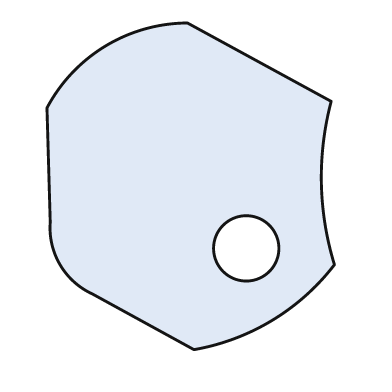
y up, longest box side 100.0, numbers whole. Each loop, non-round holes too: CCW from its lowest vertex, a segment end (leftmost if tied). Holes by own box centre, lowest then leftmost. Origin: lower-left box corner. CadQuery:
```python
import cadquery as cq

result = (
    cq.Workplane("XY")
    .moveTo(45.0, 0.0)
    .threePointArc((69.0, 9.0), (88.0, 26.0))
    .threePointArc((84.0, 51.0), (87.0, 76.0))
    .lineTo(43.0, 100.0)
    .threePointArc((18.0, 93.0), (0.0, 74.0))
    .lineTo(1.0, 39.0)
    .threePointArc((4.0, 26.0), (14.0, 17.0))
    .close()
    .moveTo(61.0, 31.0)
    .circle(10.0)
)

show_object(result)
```